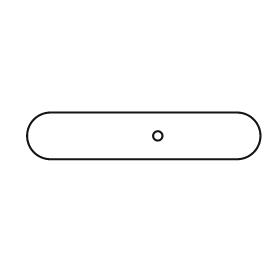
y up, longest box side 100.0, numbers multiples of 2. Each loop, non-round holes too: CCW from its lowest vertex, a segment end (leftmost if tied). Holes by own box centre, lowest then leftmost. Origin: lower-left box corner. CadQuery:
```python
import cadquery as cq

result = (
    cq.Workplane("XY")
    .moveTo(10.0, 0.0)
    .lineTo(90.0, 0.0)
    .threePointArc((100.0, 10.0), (90.0, 20.0))
    .lineTo(10.0, 20.0)
    .threePointArc((0.0, 10.0), (10.0, 0.0))
    .close()
    .moveTo(56.0, 10.0)
    .circle(2.0)
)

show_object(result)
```